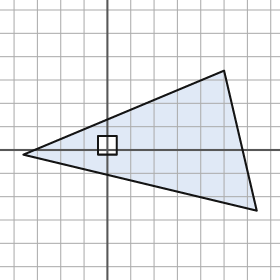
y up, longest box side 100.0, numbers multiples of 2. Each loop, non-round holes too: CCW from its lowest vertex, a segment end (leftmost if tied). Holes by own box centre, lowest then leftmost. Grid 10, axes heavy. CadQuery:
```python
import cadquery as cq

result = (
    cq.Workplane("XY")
    .moveTo(64.0, -26.0)
    .lineTo(50.0, 34.0)
    .lineTo(-36.0, -2.0)
    .close()
    .moveTo(-4.0, -2.0)
    .lineTo(4.0, -2.0)
    .lineTo(4.0, 6.0)
    .lineTo(-4.0, 6.0)
    .close()
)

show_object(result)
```